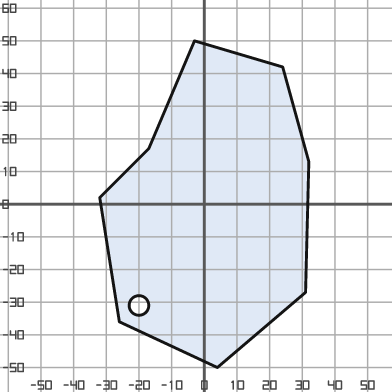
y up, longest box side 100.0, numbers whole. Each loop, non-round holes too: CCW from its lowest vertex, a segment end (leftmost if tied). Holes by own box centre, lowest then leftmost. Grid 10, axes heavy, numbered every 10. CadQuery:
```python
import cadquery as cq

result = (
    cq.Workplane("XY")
    .moveTo(4.0, -50.0)
    .lineTo(31.0, -27.0)
    .lineTo(32.0, 13.0)
    .lineTo(24.0, 42.0)
    .lineTo(-3.0, 50.0)
    .lineTo(-17.0, 17.0)
    .lineTo(-32.0, 2.0)
    .lineTo(-26.0, -36.0)
    .close()
    .moveTo(-20.0, -31.0)
    .circle(3.0)
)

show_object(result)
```